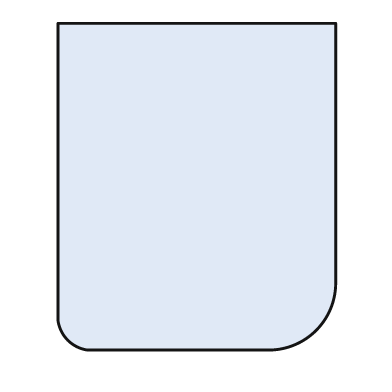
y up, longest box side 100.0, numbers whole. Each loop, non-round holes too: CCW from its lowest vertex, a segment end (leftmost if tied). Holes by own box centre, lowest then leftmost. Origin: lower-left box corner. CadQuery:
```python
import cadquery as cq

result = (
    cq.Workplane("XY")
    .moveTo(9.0, 0.0)
    .lineTo(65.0, 0.0)
    .threePointArc((79.0, 6.0), (85.0, 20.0))
    .lineTo(85.0, 100.0)
    .lineTo(0.0, 100.0)
    .lineTo(0.0, 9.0)
    .threePointArc((3.0, 3.0), (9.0, 0.0))
    .close()
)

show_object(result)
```